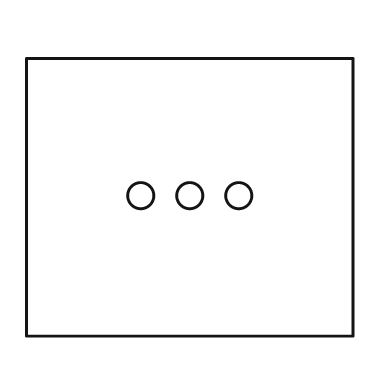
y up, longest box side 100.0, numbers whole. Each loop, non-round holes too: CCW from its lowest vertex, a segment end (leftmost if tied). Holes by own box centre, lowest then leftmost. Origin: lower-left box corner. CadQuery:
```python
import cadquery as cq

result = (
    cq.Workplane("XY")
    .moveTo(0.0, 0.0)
    .lineTo(100.0, 0.0)
    .lineTo(100.0, 85.0)
    .lineTo(0.0, 85.0)
    .close()
    .moveTo(35.0, 43.0)
    .circle(4.0)
    .moveTo(50.0, 43.0)
    .circle(4.0)
    .moveTo(65.0, 43.0)
    .circle(4.0)
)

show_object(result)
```